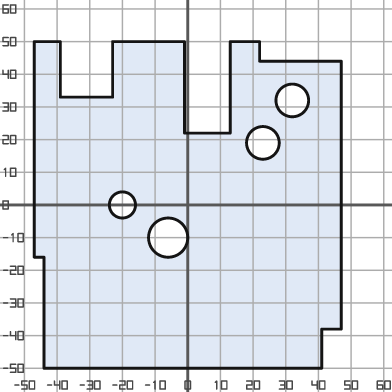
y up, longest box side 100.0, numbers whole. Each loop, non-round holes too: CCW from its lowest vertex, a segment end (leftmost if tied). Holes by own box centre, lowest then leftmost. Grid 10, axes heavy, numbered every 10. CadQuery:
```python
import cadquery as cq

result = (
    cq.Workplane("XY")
    .moveTo(-44.0, -50.0)
    .lineTo(41.0, -50.0)
    .lineTo(41.0, -38.0)
    .lineTo(47.0, -38.0)
    .lineTo(47.0, 44.0)
    .lineTo(22.0, 44.0)
    .lineTo(22.0, 50.0)
    .lineTo(13.0, 50.0)
    .lineTo(13.0, 22.0)
    .lineTo(-1.0, 22.0)
    .lineTo(-1.0, 50.0)
    .lineTo(-23.0, 50.0)
    .lineTo(-23.0, 33.0)
    .lineTo(-39.0, 33.0)
    .lineTo(-39.0, 50.0)
    .lineTo(-47.0, 50.0)
    .lineTo(-47.0, -16.0)
    .lineTo(-44.0, -16.0)
    .close()
    .moveTo(-6.0, -10.0)
    .circle(6.0)
    .moveTo(-20.0, 0.0)
    .circle(4.0)
    .moveTo(23.0, 19.0)
    .circle(5.0)
    .moveTo(32.0, 32.0)
    .circle(5.0)
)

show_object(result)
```